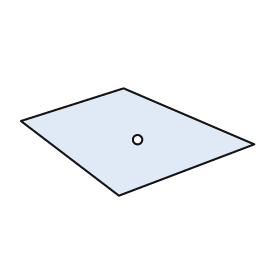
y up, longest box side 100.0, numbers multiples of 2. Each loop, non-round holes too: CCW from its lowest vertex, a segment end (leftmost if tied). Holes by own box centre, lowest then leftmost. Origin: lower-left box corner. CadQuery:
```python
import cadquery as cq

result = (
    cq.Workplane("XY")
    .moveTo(42.0, 0.0)
    .lineTo(100.0, 22.0)
    .lineTo(44.0, 46.0)
    .lineTo(0.0, 32.0)
    .close()
    .moveTo(50.0, 24.0)
    .circle(2.0)
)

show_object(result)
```